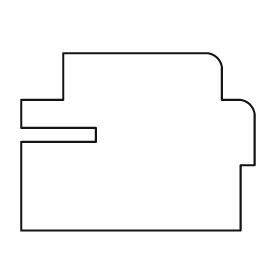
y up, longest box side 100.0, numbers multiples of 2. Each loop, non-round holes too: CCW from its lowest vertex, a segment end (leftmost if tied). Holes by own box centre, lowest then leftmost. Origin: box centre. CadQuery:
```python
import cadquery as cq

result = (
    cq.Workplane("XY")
    .moveTo(-50.0, -38.0)
    .lineTo(44.0, -38.0)
    .lineTo(44.0, -10.0)
    .lineTo(50.0, -10.0)
    .lineTo(50.0, 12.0)
    .threePointArc((48.0, 16.0), (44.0, 18.0))
    .lineTo(36.0, 18.0)
    .lineTo(36.0, 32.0)
    .threePointArc((34.0, 36.0), (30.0, 38.0))
    .lineTo(-32.0, 38.0)
    .lineTo(-32.0, 18.0)
    .lineTo(-50.0, 18.0)
    .lineTo(-50.0, 6.0)
    .lineTo(-18.0, 6.0)
    .lineTo(-18.0, 0.0)
    .lineTo(-50.0, 0.0)
    .close()
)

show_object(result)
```